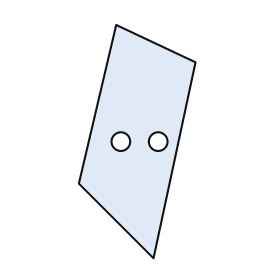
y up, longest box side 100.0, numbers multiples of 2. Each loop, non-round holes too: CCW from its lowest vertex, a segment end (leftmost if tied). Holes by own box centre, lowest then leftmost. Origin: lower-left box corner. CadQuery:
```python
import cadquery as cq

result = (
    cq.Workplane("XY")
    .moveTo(32.0, 0.0)
    .lineTo(50.0, 84.0)
    .lineTo(16.0, 100.0)
    .lineTo(0.0, 32.0)
    .close()
    .moveTo(18.0, 50.0)
    .circle(4.0)
    .moveTo(34.0, 50.0)
    .circle(4.0)
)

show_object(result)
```